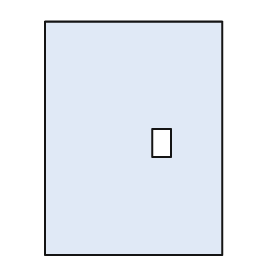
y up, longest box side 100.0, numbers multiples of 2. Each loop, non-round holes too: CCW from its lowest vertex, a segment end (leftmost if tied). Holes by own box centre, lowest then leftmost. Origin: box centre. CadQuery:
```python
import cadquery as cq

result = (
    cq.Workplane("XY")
    .moveTo(-38.0, -50.0)
    .lineTo(38.0, -50.0)
    .lineTo(38.0, 50.0)
    .lineTo(-38.0, 50.0)
    .close()
    .moveTo(8.0, -8.0)
    .lineTo(16.0, -8.0)
    .lineTo(16.0, 4.0)
    .lineTo(8.0, 4.0)
    .close()
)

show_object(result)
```